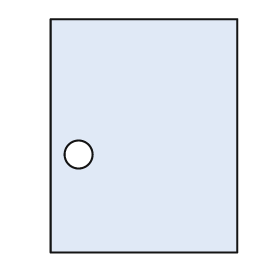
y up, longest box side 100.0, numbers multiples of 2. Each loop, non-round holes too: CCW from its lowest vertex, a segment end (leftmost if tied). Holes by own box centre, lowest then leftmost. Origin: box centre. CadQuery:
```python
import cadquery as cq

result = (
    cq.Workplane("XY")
    .moveTo(-40.0, -50.0)
    .lineTo(40.0, -50.0)
    .lineTo(40.0, 50.0)
    .lineTo(-40.0, 50.0)
    .close()
    .moveTo(-28.0, -8.0)
    .circle(6.0)
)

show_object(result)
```